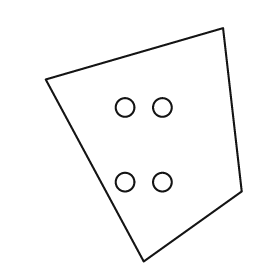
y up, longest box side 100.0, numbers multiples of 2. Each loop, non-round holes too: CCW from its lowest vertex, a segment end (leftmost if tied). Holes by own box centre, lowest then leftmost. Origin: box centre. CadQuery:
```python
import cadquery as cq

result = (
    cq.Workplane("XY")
    .moveTo(0.0, -50.0)
    .lineTo(42.0, -20.0)
    .lineTo(34.0, 50.0)
    .lineTo(-42.0, 28.0)
    .close()
    .moveTo(-8.0, -16.0)
    .circle(4.0)
    .moveTo(8.0, -16.0)
    .circle(4.0)
    .moveTo(-8.0, 16.0)
    .circle(4.0)
    .moveTo(8.0, 16.0)
    .circle(4.0)
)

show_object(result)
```